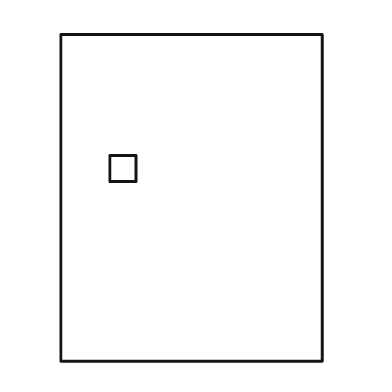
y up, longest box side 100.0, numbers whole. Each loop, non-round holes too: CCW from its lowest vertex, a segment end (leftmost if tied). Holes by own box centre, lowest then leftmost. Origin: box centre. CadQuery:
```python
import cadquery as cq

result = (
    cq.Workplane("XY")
    .moveTo(-40.0, -50.0)
    .lineTo(40.0, -50.0)
    .lineTo(40.0, 50.0)
    .lineTo(-40.0, 50.0)
    .close()
    .moveTo(-25.0, 5.0)
    .lineTo(-17.0, 5.0)
    .lineTo(-17.0, 13.0)
    .lineTo(-25.0, 13.0)
    .close()
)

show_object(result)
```